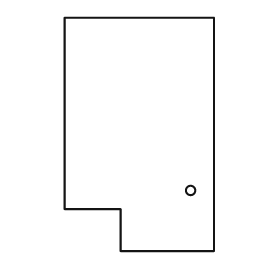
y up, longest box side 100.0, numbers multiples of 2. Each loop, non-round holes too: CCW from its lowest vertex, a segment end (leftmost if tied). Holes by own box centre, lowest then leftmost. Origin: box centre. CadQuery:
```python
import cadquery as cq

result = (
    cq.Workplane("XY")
    .moveTo(-8.0, -50.0)
    .lineTo(32.0, -50.0)
    .lineTo(32.0, 50.0)
    .lineTo(-32.0, 50.0)
    .lineTo(-32.0, -32.0)
    .lineTo(-8.0, -32.0)
    .close()
    .moveTo(22.0, -24.0)
    .circle(2.0)
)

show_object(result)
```